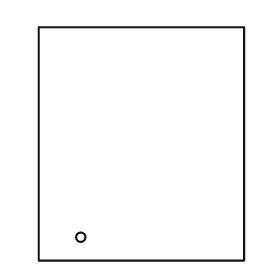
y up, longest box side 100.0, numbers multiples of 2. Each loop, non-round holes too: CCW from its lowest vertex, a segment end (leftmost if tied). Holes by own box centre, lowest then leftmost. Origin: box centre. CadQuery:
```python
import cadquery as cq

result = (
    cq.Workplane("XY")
    .moveTo(-44.0, -50.0)
    .lineTo(44.0, -50.0)
    .lineTo(44.0, 50.0)
    .lineTo(-44.0, 50.0)
    .close()
    .moveTo(-26.0, -40.0)
    .circle(2.0)
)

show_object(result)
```